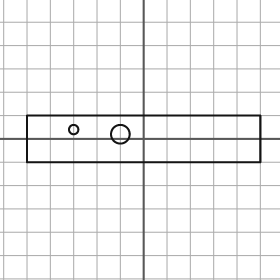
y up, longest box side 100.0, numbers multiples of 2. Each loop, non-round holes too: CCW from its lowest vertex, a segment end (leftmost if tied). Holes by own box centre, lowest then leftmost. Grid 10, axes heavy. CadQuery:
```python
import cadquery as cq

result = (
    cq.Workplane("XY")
    .moveTo(-50.0, -10.0)
    .lineTo(50.0, -10.0)
    .lineTo(50.0, 10.0)
    .lineTo(-50.0, 10.0)
    .close()
    .moveTo(-10.0, 2.0)
    .circle(4.0)
    .moveTo(-30.0, 4.0)
    .circle(2.0)
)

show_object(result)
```